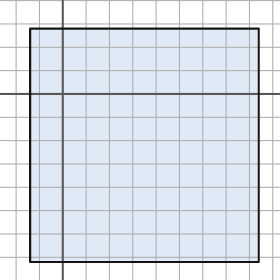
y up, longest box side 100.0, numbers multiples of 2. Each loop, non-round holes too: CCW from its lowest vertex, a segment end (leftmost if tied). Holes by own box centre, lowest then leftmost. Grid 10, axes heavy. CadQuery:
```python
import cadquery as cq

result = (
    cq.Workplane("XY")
    .moveTo(-14.0, -72.0)
    .lineTo(84.0, -72.0)
    .lineTo(84.0, 28.0)
    .lineTo(-14.0, 28.0)
    .close()
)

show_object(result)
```